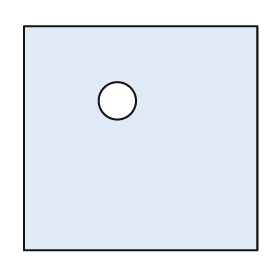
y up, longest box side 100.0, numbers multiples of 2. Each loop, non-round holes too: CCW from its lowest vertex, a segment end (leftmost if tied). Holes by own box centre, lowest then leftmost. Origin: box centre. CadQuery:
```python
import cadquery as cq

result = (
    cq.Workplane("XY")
    .moveTo(-50.0, -48.0)
    .lineTo(50.0, -48.0)
    .lineTo(50.0, 48.0)
    .lineTo(-50.0, 48.0)
    .close()
    .moveTo(-10.0, 16.0)
    .circle(8.0)
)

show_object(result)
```